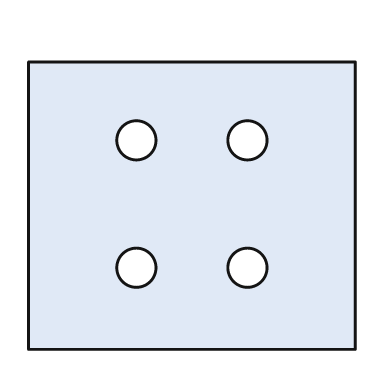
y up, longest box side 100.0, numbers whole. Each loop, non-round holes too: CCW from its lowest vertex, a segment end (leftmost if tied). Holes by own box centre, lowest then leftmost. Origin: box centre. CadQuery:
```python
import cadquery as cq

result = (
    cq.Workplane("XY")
    .moveTo(-50.0, -44.0)
    .lineTo(50.0, -44.0)
    .lineTo(50.0, 44.0)
    .lineTo(-50.0, 44.0)
    .close()
    .moveTo(-17.0, -19.0)
    .circle(6.0)
    .moveTo(17.0, -19.0)
    .circle(6.0)
    .moveTo(-17.0, 20.0)
    .circle(6.0)
    .moveTo(17.0, 20.0)
    .circle(6.0)
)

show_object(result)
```